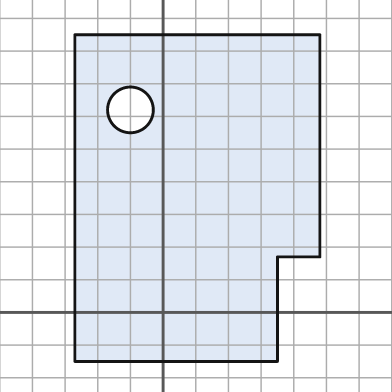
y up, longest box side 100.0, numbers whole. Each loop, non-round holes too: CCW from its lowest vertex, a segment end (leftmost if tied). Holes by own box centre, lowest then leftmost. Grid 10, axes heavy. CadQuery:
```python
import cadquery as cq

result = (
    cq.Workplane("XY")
    .moveTo(-27.0, -15.0)
    .lineTo(35.0, -15.0)
    .lineTo(35.0, 17.0)
    .lineTo(48.0, 17.0)
    .lineTo(48.0, 85.0)
    .lineTo(-27.0, 85.0)
    .close()
    .moveTo(-10.0, 62.0)
    .circle(7.0)
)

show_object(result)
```